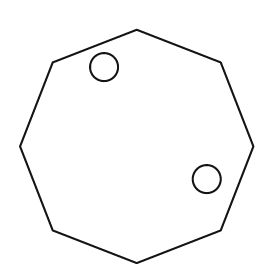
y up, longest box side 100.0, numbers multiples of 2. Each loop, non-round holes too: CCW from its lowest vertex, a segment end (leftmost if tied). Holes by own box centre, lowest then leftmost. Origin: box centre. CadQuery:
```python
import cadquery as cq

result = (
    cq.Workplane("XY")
    .moveTo(0.0, -50.0)
    .lineTo(36.0, -36.0)
    .lineTo(50.0, 0.0)
    .lineTo(36.0, 36.0)
    .lineTo(0.0, 50.0)
    .lineTo(-36.0, 36.0)
    .lineTo(-50.0, 0.0)
    .lineTo(-36.0, -36.0)
    .close()
    .moveTo(30.0, -14.0)
    .circle(6.0)
    .moveTo(-14.0, 34.0)
    .circle(6.0)
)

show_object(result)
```